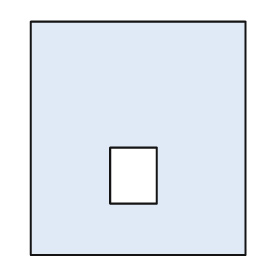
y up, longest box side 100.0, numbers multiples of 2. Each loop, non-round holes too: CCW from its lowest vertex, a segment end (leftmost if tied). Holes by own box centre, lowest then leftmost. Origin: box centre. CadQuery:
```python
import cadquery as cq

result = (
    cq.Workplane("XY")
    .moveTo(-46.0, -50.0)
    .lineTo(46.0, -50.0)
    .lineTo(46.0, 50.0)
    .lineTo(-46.0, 50.0)
    .close()
    .moveTo(-12.0, -28.0)
    .lineTo(8.0, -28.0)
    .lineTo(8.0, -4.0)
    .lineTo(-12.0, -4.0)
    .close()
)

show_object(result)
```